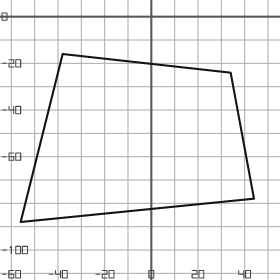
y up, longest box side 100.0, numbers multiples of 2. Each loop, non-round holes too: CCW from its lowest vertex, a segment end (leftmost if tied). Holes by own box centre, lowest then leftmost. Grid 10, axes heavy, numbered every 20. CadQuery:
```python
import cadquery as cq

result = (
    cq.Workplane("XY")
    .moveTo(-56.0, -88.0)
    .lineTo(44.0, -78.0)
    .lineTo(34.0, -24.0)
    .lineTo(-38.0, -16.0)
    .close()
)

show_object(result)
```